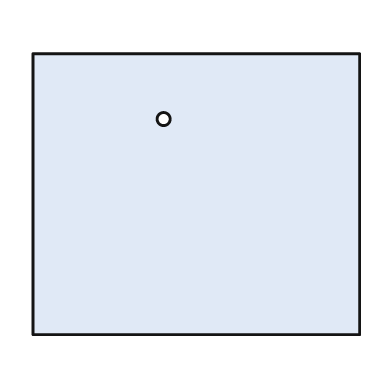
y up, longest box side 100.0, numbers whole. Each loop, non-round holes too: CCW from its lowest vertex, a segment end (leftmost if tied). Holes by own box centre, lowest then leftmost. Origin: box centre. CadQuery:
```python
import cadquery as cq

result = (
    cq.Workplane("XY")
    .moveTo(-50.0, -43.0)
    .lineTo(50.0, -43.0)
    .lineTo(50.0, 43.0)
    .lineTo(-50.0, 43.0)
    .close()
    .moveTo(-10.0, 23.0)
    .circle(2.0)
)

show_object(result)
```